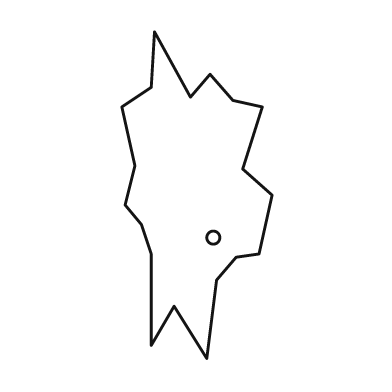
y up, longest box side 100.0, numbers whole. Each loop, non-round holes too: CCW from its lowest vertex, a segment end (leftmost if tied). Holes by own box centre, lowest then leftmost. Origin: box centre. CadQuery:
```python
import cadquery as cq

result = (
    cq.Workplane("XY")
    .moveTo(3.0, -50.0)
    .lineTo(6.0, -26.0)
    .lineTo(12.0, -19.0)
    .lineTo(19.0, -18.0)
    .lineTo(23.0, 0.0)
    .lineTo(14.0, 8.0)
    .lineTo(20.0, 27.0)
    .lineTo(11.0, 29.0)
    .lineTo(4.0, 37.0)
    .lineTo(-2.0, 30.0)
    .lineTo(-13.0, 50.0)
    .lineTo(-14.0, 33.0)
    .lineTo(-23.0, 27.0)
    .lineTo(-19.0, 9.0)
    .lineTo(-22.0, -3.0)
    .lineTo(-17.0, -9.0)
    .lineTo(-14.0, -18.0)
    .lineTo(-14.0, -46.0)
    .lineTo(-7.0, -34.0)
    .close()
    .moveTo(5.0, -13.0)
    .circle(2.0)
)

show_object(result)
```